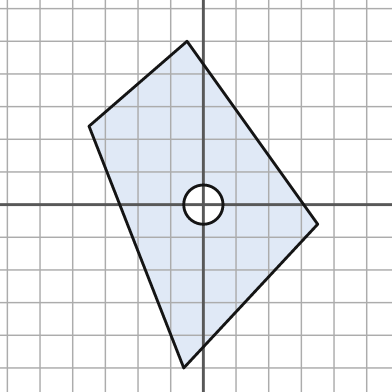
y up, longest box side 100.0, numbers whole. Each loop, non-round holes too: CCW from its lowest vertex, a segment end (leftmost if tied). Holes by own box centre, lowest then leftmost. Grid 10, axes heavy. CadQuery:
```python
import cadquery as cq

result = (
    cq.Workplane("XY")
    .moveTo(-6.0, -50.0)
    .lineTo(35.0, -6.0)
    .lineTo(-5.0, 50.0)
    .lineTo(-35.0, 24.0)
    .close()
    .moveTo(0.0, 0.0)
    .circle(6.0)
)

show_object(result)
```